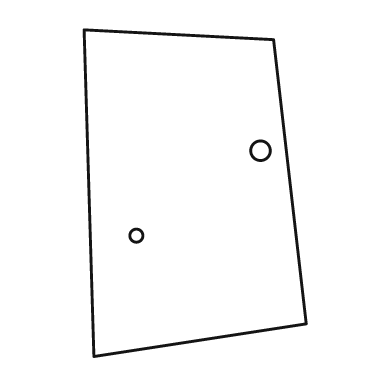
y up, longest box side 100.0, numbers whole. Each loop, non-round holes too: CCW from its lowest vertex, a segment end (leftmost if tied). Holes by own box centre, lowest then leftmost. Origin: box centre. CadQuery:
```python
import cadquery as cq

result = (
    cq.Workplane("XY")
    .moveTo(-31.0, -50.0)
    .lineTo(34.0, -40.0)
    .lineTo(24.0, 47.0)
    .lineTo(-34.0, 50.0)
    .close()
    .moveTo(-18.0, -13.0)
    .circle(2.0)
    .moveTo(20.0, 13.0)
    .circle(3.0)
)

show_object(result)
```